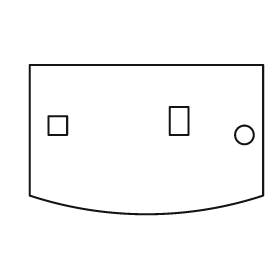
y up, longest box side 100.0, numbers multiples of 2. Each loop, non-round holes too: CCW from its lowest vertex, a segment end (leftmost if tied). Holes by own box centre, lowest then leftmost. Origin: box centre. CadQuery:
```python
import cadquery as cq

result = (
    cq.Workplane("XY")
    .moveTo(-50.0, -24.0)
    .threePointArc((0.0, -32.0), (50.0, -24.0))
    .lineTo(50.0, 32.0)
    .lineTo(-50.0, 32.0)
    .close()
    .moveTo(42.0, 2.0)
    .circle(4.0)
    .moveTo(-42.0, 2.0)
    .lineTo(-34.0, 2.0)
    .lineTo(-34.0, 10.0)
    .lineTo(-42.0, 10.0)
    .close()
    .moveTo(10.0, 2.0)
    .lineTo(18.0, 2.0)
    .lineTo(18.0, 14.0)
    .lineTo(10.0, 14.0)
    .close()
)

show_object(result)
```